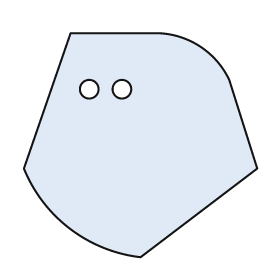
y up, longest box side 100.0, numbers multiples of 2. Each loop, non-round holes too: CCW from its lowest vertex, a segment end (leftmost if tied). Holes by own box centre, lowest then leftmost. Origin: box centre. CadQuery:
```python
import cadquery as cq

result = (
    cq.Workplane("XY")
    .moveTo(0.0, -48.0)
    .lineTo(50.0, -10.0)
    .lineTo(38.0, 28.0)
    .threePointArc((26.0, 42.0), (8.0, 48.0))
    .lineTo(-30.0, 48.0)
    .lineTo(-50.0, -10.0)
    .threePointArc((-30.0, -36.0), (0.0, -48.0))
    .close()
    .moveTo(-22.0, 24.0)
    .circle(4.0)
    .moveTo(-8.0, 24.0)
    .circle(4.0)
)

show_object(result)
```